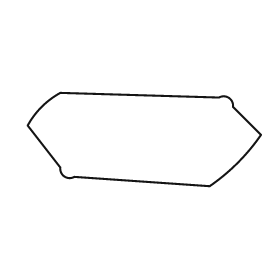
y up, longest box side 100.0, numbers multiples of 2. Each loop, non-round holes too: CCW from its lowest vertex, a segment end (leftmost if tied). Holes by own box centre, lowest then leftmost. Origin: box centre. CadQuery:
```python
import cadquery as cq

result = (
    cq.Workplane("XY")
    .moveTo(28.0, -20.0)
    .threePointArc((40.0, -10.0), (50.0, 2.0))
    .lineTo(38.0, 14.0)
    .threePointArc((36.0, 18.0), (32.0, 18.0))
    .lineTo(-36.0, 20.0)
    .threePointArc((-44.0, 14.0), (-50.0, 6.0))
    .lineTo(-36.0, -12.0)
    .threePointArc((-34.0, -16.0), (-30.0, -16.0))
    .close()
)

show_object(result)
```